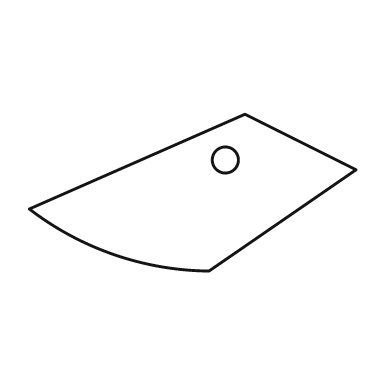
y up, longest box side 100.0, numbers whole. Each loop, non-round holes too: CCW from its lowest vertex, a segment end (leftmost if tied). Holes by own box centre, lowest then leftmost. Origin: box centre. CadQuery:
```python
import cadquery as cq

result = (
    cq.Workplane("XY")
    .moveTo(5.0, -24.0)
    .lineTo(50.0, 7.0)
    .lineTo(16.0, 24.0)
    .lineTo(-50.0, -5.0)
    .threePointArc((-24.0, -19.0), (5.0, -24.0))
    .close()
    .moveTo(10.0, 10.0)
    .circle(4.0)
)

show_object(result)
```